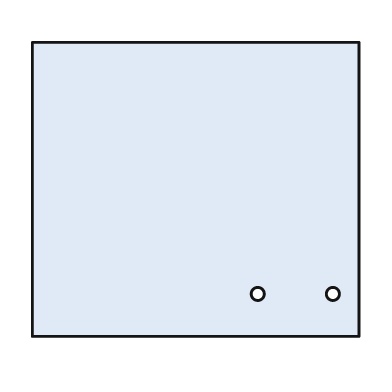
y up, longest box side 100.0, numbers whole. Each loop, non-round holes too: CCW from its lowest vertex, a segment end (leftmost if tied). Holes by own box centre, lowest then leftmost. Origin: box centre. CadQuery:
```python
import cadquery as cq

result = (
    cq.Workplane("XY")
    .moveTo(-50.0, -45.0)
    .lineTo(50.0, -45.0)
    .lineTo(50.0, 45.0)
    .lineTo(-50.0, 45.0)
    .close()
    .moveTo(19.0, -32.0)
    .circle(2.0)
    .moveTo(42.0, -32.0)
    .circle(2.0)
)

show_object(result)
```